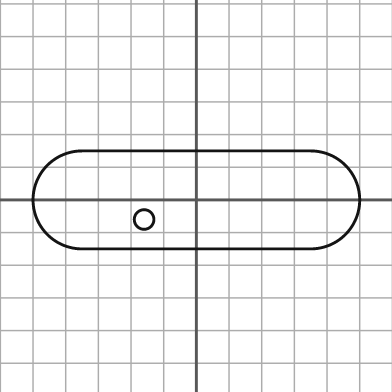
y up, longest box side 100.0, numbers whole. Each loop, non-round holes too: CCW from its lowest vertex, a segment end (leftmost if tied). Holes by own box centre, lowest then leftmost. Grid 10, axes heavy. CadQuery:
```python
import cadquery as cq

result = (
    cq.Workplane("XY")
    .moveTo(-35.0, -15.0)
    .lineTo(35.0, -15.0)
    .threePointArc((50.0, 0.0), (35.0, 15.0))
    .lineTo(-35.0, 15.0)
    .threePointArc((-50.0, 0.0), (-35.0, -15.0))
    .close()
    .moveTo(-16.0, -6.0)
    .circle(3.0)
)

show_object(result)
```